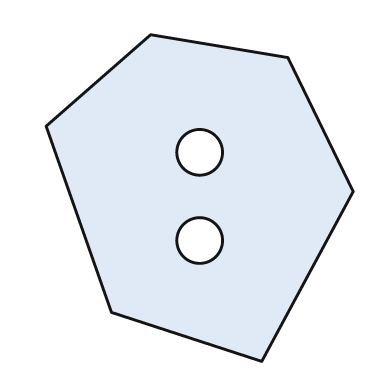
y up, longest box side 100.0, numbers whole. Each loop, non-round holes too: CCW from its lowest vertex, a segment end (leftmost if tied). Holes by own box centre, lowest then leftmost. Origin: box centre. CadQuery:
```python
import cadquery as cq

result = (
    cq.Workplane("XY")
    .moveTo(19.0, -50.0)
    .lineTo(47.0, 2.0)
    .lineTo(27.0, 43.0)
    .lineTo(-15.0, 50.0)
    .lineTo(-47.0, 22.0)
    .lineTo(-27.0, -35.0)
    .close()
    .moveTo(0.0, -13.0)
    .circle(7.0)
    .moveTo(0.0, 14.0)
    .circle(7.0)
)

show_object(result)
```